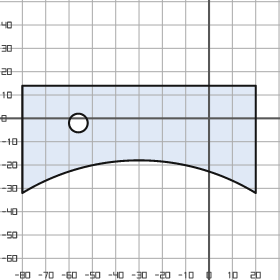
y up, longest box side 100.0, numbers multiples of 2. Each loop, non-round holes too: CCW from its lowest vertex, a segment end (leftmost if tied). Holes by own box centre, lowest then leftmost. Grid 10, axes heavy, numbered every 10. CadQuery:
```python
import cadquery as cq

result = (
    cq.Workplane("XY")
    .moveTo(-80.0, -32.0)
    .threePointArc((-30.0, -18.0), (20.0, -32.0))
    .lineTo(20.0, 14.0)
    .lineTo(-80.0, 14.0)
    .close()
    .moveTo(-56.0, -2.0)
    .circle(4.0)
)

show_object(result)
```